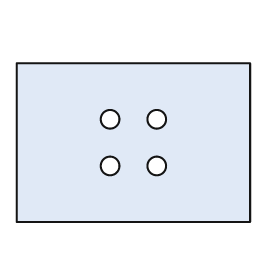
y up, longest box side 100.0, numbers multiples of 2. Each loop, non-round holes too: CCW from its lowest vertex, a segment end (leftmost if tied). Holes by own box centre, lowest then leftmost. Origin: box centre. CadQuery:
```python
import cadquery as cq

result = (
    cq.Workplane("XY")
    .moveTo(-50.0, -34.0)
    .lineTo(50.0, -34.0)
    .lineTo(50.0, 34.0)
    .lineTo(-50.0, 34.0)
    .close()
    .moveTo(-10.0, -10.0)
    .circle(4.0)
    .moveTo(10.0, -10.0)
    .circle(4.0)
    .moveTo(-10.0, 10.0)
    .circle(4.0)
    .moveTo(10.0, 10.0)
    .circle(4.0)
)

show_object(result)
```